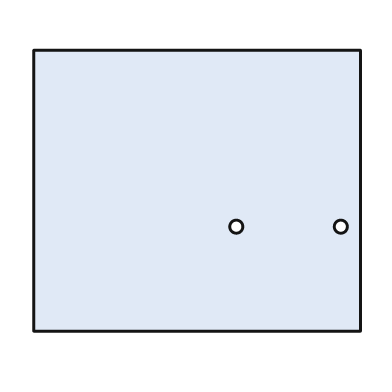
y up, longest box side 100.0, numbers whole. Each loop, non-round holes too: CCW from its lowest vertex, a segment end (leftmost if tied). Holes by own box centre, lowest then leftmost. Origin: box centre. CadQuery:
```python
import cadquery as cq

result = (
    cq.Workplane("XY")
    .moveTo(-50.0, -43.0)
    .lineTo(50.0, -43.0)
    .lineTo(50.0, 43.0)
    .lineTo(-50.0, 43.0)
    .close()
    .moveTo(12.0, -11.0)
    .circle(2.0)
    .moveTo(44.0, -11.0)
    .circle(2.0)
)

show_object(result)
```